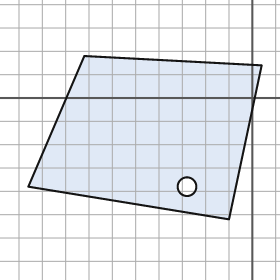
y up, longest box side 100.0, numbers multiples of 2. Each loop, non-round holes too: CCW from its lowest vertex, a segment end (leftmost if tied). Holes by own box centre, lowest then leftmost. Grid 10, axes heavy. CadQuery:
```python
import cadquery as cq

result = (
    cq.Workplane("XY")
    .moveTo(-10.0, -52.0)
    .lineTo(4.0, 14.0)
    .lineTo(-72.0, 18.0)
    .lineTo(-96.0, -38.0)
    .close()
    .moveTo(-28.0, -38.0)
    .circle(4.0)
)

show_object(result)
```